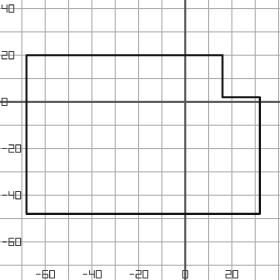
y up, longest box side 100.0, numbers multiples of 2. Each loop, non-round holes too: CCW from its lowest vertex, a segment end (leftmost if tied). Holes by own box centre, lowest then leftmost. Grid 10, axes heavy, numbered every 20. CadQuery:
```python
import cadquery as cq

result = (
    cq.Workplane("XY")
    .moveTo(-68.0, -48.0)
    .lineTo(32.0, -48.0)
    .lineTo(32.0, 2.0)
    .lineTo(16.0, 2.0)
    .lineTo(16.0, 20.0)
    .lineTo(-68.0, 20.0)
    .close()
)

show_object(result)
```